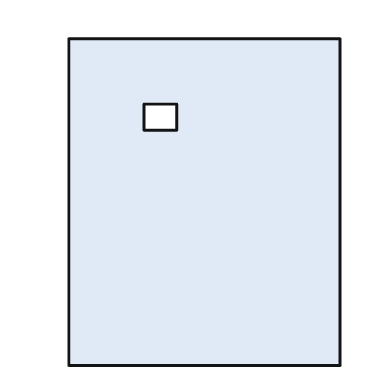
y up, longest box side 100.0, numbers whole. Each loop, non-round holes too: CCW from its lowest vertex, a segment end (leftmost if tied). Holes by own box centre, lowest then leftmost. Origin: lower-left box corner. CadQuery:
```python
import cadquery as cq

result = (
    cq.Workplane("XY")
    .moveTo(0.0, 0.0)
    .lineTo(83.0, 0.0)
    .lineTo(83.0, 100.0)
    .lineTo(0.0, 100.0)
    .close()
    .moveTo(23.0, 72.0)
    .lineTo(33.0, 72.0)
    .lineTo(33.0, 80.0)
    .lineTo(23.0, 80.0)
    .close()
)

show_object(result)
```